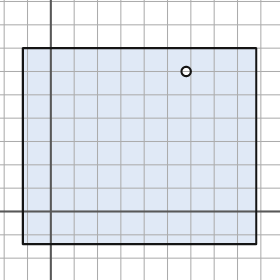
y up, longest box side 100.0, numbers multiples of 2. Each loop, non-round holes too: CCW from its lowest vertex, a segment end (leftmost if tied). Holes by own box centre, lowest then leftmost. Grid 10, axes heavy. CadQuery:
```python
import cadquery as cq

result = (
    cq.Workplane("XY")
    .moveTo(-12.0, -14.0)
    .lineTo(88.0, -14.0)
    .lineTo(88.0, 70.0)
    .lineTo(-12.0, 70.0)
    .close()
    .moveTo(58.0, 60.0)
    .circle(2.0)
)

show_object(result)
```